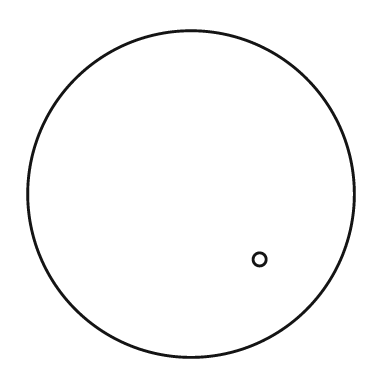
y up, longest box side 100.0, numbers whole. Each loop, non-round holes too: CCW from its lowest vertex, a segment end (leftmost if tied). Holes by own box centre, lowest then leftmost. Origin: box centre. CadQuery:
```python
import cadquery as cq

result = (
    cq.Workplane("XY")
    .moveTo(0.0, 0.0)
    .circle(50.0)
    .moveTo(21.0, -20.0)
    .circle(2.0)
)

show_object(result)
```